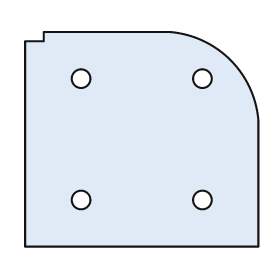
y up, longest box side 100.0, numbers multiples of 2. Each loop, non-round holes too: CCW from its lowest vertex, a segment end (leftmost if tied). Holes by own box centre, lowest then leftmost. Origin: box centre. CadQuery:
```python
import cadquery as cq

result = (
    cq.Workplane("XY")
    .moveTo(-50.0, -46.0)
    .lineTo(50.0, -46.0)
    .lineTo(50.0, 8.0)
    .threePointArc((38.0, 34.0), (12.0, 46.0))
    .lineTo(-42.0, 46.0)
    .lineTo(-42.0, 42.0)
    .lineTo(-50.0, 42.0)
    .close()
    .moveTo(-26.0, -26.0)
    .circle(4.0)
    .moveTo(26.0, -26.0)
    .circle(4.0)
    .moveTo(-26.0, 26.0)
    .circle(4.0)
    .moveTo(26.0, 26.0)
    .circle(4.0)
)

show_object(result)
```